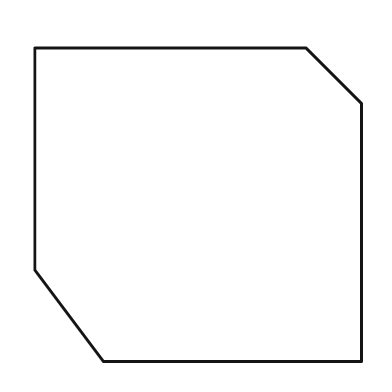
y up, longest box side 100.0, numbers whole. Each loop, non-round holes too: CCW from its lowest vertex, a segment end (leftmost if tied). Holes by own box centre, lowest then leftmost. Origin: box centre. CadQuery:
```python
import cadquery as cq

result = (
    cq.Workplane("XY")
    .moveTo(-29.0, -48.0)
    .lineTo(50.0, -48.0)
    .lineTo(50.0, 31.0)
    .lineTo(33.0, 48.0)
    .lineTo(-50.0, 48.0)
    .lineTo(-50.0, -20.0)
    .close()
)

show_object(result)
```